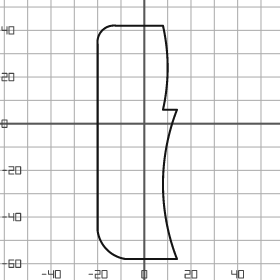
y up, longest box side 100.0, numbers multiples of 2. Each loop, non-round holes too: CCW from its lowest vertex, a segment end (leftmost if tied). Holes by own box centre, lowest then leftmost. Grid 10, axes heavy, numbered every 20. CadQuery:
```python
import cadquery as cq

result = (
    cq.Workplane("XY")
    .moveTo(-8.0, -58.0)
    .lineTo(14.0, -58.0)
    .threePointArc((8.0, -26.0), (14.0, 6.0))
    .lineTo(8.0, 6.0)
    .threePointArc((10.0, 24.0), (8.0, 42.0))
    .lineTo(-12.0, 42.0)
    .threePointArc((-18.0, 40.0), (-20.0, 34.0))
    .lineTo(-20.0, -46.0)
    .threePointArc((-16.0, -54.0), (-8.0, -58.0))
    .close()
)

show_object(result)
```